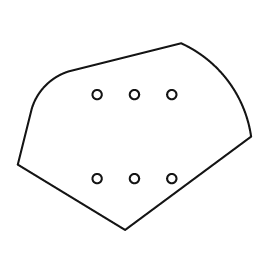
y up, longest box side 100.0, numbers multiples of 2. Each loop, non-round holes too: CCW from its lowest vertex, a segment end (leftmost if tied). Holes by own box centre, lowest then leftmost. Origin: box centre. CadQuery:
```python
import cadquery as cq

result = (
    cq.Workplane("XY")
    .moveTo(-4.0, -40.0)
    .lineTo(50.0, 0.0)
    .threePointArc((40.0, 24.0), (20.0, 40.0))
    .lineTo(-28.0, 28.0)
    .threePointArc((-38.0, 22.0), (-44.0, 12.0))
    .lineTo(-50.0, -12.0)
    .close()
    .moveTo(-16.0, -18.0)
    .circle(2.0)
    .moveTo(0.0, -18.0)
    .circle(2.0)
    .moveTo(16.0, -18.0)
    .circle(2.0)
    .moveTo(-16.0, 18.0)
    .circle(2.0)
    .moveTo(0.0, 18.0)
    .circle(2.0)
    .moveTo(16.0, 18.0)
    .circle(2.0)
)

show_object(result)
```